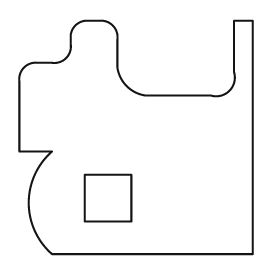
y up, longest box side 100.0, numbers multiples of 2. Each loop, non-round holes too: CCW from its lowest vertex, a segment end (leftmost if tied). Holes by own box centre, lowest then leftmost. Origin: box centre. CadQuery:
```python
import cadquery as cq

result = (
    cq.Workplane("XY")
    .moveTo(-36.0, -50.0)
    .lineTo(50.0, -50.0)
    .lineTo(50.0, 50.0)
    .lineTo(42.0, 50.0)
    .lineTo(42.0, 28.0)
    .threePointArc((40.0, 20.0), (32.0, 18.0))
    .lineTo(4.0, 18.0)
    .threePointArc((-4.0, 22.0), (-8.0, 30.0))
    .lineTo(-8.0, 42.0)
    .threePointArc((-10.0, 48.0), (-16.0, 50.0))
    .lineTo(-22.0, 50.0)
    .threePointArc((-26.0, 48.0), (-28.0, 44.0))
    .lineTo(-28.0, 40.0)
    .threePointArc((-30.0, 34.0), (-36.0, 32.0))
    .lineTo(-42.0, 32.0)
    .threePointArc((-48.0, 30.0), (-50.0, 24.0))
    .lineTo(-50.0, -6.0)
    .lineTo(-36.0, -6.0)
    .threePointArc((-46.0, -28.0), (-36.0, -50.0))
    .close()
    .moveTo(-22.0, -36.0)
    .lineTo(-2.0, -36.0)
    .lineTo(-2.0, -16.0)
    .lineTo(-22.0, -16.0)
    .close()
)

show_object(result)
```